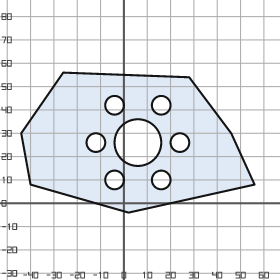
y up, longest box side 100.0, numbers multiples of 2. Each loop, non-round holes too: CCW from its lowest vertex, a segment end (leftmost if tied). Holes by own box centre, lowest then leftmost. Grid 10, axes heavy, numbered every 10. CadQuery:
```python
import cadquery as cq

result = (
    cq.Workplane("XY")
    .moveTo(2.0, -4.0)
    .lineTo(56.0, 8.0)
    .lineTo(46.0, 30.0)
    .lineTo(28.0, 54.0)
    .lineTo(-26.0, 56.0)
    .lineTo(-44.0, 30.0)
    .lineTo(-40.0, 8.0)
    .close()
    .moveTo(-4.0, 10.0)
    .circle(4.0)
    .moveTo(16.0, 10.0)
    .circle(4.0)
    .moveTo(-12.0, 26.0)
    .circle(4.0)
    .moveTo(6.0, 26.0)
    .circle(10.0)
    .moveTo(24.0, 26.0)
    .circle(4.0)
    .moveTo(-4.0, 42.0)
    .circle(4.0)
    .moveTo(16.0, 42.0)
    .circle(4.0)
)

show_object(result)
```